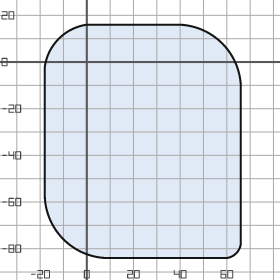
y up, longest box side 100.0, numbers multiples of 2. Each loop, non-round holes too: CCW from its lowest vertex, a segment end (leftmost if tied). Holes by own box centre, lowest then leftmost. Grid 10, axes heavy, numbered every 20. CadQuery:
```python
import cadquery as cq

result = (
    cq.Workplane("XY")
    .moveTo(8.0, -84.0)
    .lineTo(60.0, -84.0)
    .threePointArc((64.0, -82.0), (66.0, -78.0))
    .lineTo(66.0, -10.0)
    .threePointArc((58.0, 8.0), (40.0, 16.0))
    .lineTo(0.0, 16.0)
    .threePointArc((-12.0, 10.0), (-18.0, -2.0))
    .lineTo(-18.0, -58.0)
    .threePointArc((-10.0, -76.0), (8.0, -84.0))
    .close()
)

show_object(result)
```